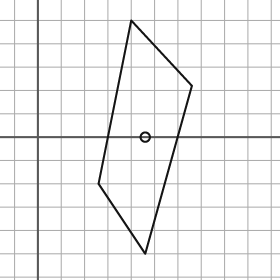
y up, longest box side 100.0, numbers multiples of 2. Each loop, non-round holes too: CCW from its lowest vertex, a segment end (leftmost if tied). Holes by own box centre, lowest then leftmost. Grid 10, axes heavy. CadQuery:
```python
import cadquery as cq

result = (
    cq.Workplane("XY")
    .moveTo(46.0, -50.0)
    .lineTo(66.0, 22.0)
    .lineTo(40.0, 50.0)
    .lineTo(26.0, -20.0)
    .close()
    .moveTo(46.0, 0.0)
    .circle(2.0)
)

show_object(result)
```